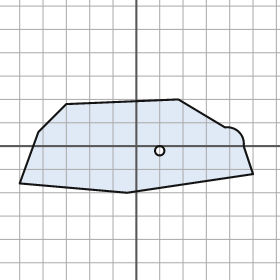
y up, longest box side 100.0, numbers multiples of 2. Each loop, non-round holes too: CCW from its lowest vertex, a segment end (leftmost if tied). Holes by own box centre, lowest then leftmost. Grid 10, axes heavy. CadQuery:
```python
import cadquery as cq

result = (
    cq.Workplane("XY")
    .moveTo(-4.0, -20.0)
    .lineTo(50.0, -12.0)
    .lineTo(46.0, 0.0)
    .threePointArc((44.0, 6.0), (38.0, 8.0))
    .lineTo(18.0, 20.0)
    .lineTo(-30.0, 18.0)
    .lineTo(-42.0, 6.0)
    .lineTo(-50.0, -16.0)
    .close()
    .moveTo(10.0, -2.0)
    .circle(2.0)
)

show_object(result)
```